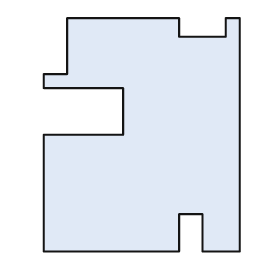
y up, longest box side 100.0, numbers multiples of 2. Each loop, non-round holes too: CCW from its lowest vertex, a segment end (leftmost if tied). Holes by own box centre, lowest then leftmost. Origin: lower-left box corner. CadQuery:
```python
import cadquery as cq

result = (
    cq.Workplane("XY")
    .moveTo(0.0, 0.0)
    .lineTo(58.0, 0.0)
    .lineTo(58.0, 16.0)
    .lineTo(68.0, 16.0)
    .lineTo(68.0, 0.0)
    .lineTo(84.0, 0.0)
    .lineTo(84.0, 100.0)
    .lineTo(78.0, 100.0)
    .lineTo(78.0, 92.0)
    .lineTo(58.0, 92.0)
    .lineTo(58.0, 100.0)
    .lineTo(10.0, 100.0)
    .lineTo(10.0, 76.0)
    .lineTo(0.0, 76.0)
    .lineTo(0.0, 70.0)
    .lineTo(34.0, 70.0)
    .lineTo(34.0, 50.0)
    .lineTo(0.0, 50.0)
    .close()
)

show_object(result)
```